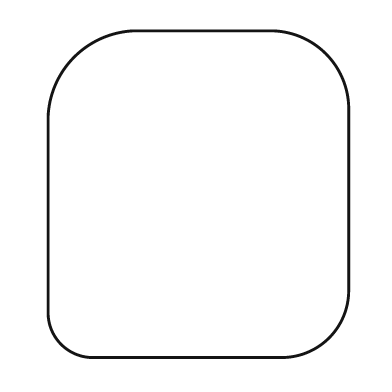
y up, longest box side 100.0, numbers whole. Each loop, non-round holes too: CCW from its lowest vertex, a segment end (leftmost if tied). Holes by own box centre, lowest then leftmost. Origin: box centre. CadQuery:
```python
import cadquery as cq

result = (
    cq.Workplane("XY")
    .moveTo(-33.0, -50.0)
    .lineTo(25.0, -50.0)
    .threePointArc((40.0, -44.0), (46.0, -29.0))
    .lineTo(46.0, 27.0)
    .threePointArc((39.0, 43.0), (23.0, 50.0))
    .lineTo(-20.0, 50.0)
    .threePointArc((-38.0, 42.0), (-46.0, 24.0))
    .lineTo(-46.0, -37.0)
    .threePointArc((-42.0, -46.0), (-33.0, -50.0))
    .close()
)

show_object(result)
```